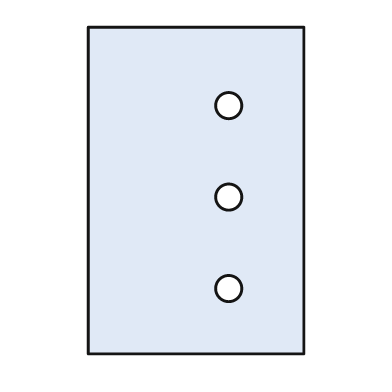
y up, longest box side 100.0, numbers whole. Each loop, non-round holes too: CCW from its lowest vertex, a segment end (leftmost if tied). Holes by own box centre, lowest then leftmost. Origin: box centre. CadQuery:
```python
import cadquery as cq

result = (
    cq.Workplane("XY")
    .moveTo(-33.0, -50.0)
    .lineTo(33.0, -50.0)
    .lineTo(33.0, 50.0)
    .lineTo(-33.0, 50.0)
    .close()
    .moveTo(10.0, -30.0)
    .circle(4.0)
    .moveTo(10.0, -2.0)
    .circle(4.0)
    .moveTo(10.0, 26.0)
    .circle(4.0)
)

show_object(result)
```